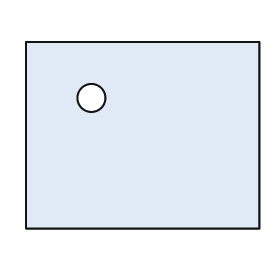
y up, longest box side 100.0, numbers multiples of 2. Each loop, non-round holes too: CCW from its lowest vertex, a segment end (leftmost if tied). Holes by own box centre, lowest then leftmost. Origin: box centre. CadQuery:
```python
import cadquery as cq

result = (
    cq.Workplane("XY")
    .moveTo(-50.0, -40.0)
    .lineTo(50.0, -40.0)
    .lineTo(50.0, 40.0)
    .lineTo(-50.0, 40.0)
    .close()
    .moveTo(-22.0, 16.0)
    .circle(6.0)
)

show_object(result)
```